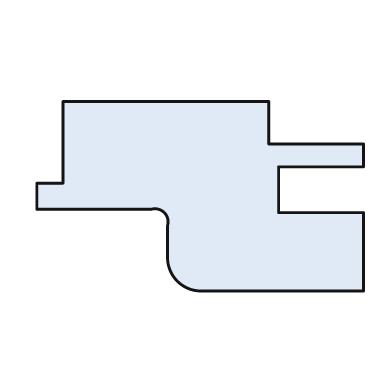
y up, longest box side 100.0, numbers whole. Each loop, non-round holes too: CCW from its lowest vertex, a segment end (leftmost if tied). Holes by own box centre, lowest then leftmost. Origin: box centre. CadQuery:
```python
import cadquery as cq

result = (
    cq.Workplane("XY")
    .moveTo(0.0, -29.0)
    .lineTo(50.0, -29.0)
    .lineTo(50.0, -5.0)
    .lineTo(24.0, -5.0)
    .lineTo(24.0, 9.0)
    .lineTo(50.0, 9.0)
    .lineTo(50.0, 16.0)
    .lineTo(21.0, 16.0)
    .lineTo(21.0, 29.0)
    .lineTo(-42.0, 29.0)
    .lineTo(-42.0, 4.0)
    .lineTo(-50.0, 4.0)
    .lineTo(-50.0, -4.0)
    .lineTo(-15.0, -4.0)
    .threePointArc((-11.0, -5.0), (-10.0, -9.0))
    .lineTo(-10.0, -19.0)
    .threePointArc((-7.0, -26.0), (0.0, -29.0))
    .close()
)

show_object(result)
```